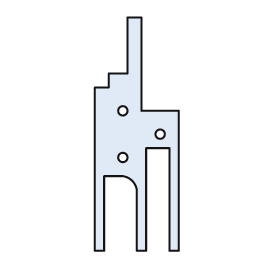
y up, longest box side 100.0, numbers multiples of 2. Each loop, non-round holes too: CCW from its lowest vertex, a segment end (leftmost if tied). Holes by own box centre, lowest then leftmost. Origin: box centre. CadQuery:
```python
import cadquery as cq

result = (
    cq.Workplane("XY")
    .moveTo(-18.0, -50.0)
    .lineTo(-14.0, -50.0)
    .lineTo(-14.0, -18.0)
    .lineTo(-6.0, -18.0)
    .threePointArc((-2.0, -20.0), (0.0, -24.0))
    .lineTo(0.0, -50.0)
    .lineTo(4.0, -50.0)
    .lineTo(4.0, -6.0)
    .lineTo(14.0, -6.0)
    .lineTo(14.0, -50.0)
    .lineTo(18.0, -50.0)
    .lineTo(18.0, 10.0)
    .lineTo(2.0, 10.0)
    .lineTo(2.0, 50.0)
    .lineTo(-4.0, 50.0)
    .lineTo(-4.0, 26.0)
    .lineTo(-12.0, 26.0)
    .lineTo(-12.0, 20.0)
    .lineTo(-18.0, 20.0)
    .close()
    .moveTo(-6.0, -10.0)
    .circle(2.0)
    .moveTo(10.0, 0.0)
    .circle(2.0)
    .moveTo(-6.0, 10.0)
    .circle(2.0)
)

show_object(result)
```